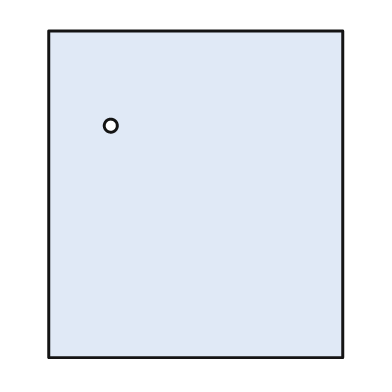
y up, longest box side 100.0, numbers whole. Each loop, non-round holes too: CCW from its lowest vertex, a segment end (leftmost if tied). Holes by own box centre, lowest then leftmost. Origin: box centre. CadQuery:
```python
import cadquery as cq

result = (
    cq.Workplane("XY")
    .moveTo(-45.0, -50.0)
    .lineTo(45.0, -50.0)
    .lineTo(45.0, 50.0)
    .lineTo(-45.0, 50.0)
    .close()
    .moveTo(-26.0, 21.0)
    .circle(2.0)
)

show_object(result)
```